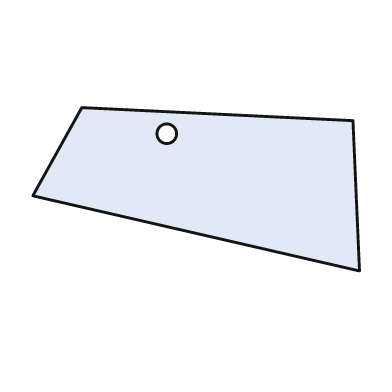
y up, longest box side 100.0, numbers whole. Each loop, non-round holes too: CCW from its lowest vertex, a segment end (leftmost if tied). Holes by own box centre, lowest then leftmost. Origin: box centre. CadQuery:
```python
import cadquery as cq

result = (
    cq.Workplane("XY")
    .moveTo(50.0, -25.0)
    .lineTo(48.0, 21.0)
    .lineTo(-35.0, 25.0)
    .lineTo(-50.0, -2.0)
    .close()
    .moveTo(-9.0, 17.0)
    .circle(3.0)
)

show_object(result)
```